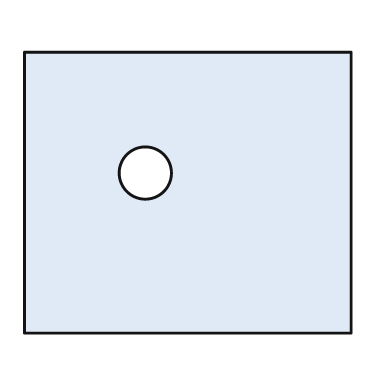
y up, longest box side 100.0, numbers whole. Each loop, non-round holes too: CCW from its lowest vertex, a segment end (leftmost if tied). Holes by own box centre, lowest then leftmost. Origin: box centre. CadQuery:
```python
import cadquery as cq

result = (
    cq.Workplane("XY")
    .moveTo(-50.0, -43.0)
    .lineTo(50.0, -43.0)
    .lineTo(50.0, 43.0)
    .lineTo(-50.0, 43.0)
    .close()
    .moveTo(-13.0, 6.0)
    .circle(8.0)
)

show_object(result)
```